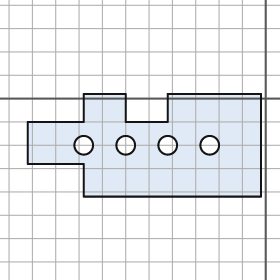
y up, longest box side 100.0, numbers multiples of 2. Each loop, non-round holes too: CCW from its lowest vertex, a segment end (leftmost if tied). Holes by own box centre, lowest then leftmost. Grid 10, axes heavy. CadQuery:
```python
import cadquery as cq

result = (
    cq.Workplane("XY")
    .moveTo(-78.0, -42.0)
    .lineTo(-2.0, -42.0)
    .lineTo(-2.0, 2.0)
    .lineTo(-42.0, 2.0)
    .lineTo(-42.0, -10.0)
    .lineTo(-60.0, -10.0)
    .lineTo(-60.0, 2.0)
    .lineTo(-78.0, 2.0)
    .lineTo(-78.0, -10.0)
    .lineTo(-102.0, -10.0)
    .lineTo(-102.0, -28.0)
    .lineTo(-78.0, -28.0)
    .close()
    .moveTo(-78.0, -20.0)
    .circle(4.0)
    .moveTo(-60.0, -20.0)
    .circle(4.0)
    .moveTo(-42.0, -20.0)
    .circle(4.0)
    .moveTo(-24.0, -20.0)
    .circle(4.0)
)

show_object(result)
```